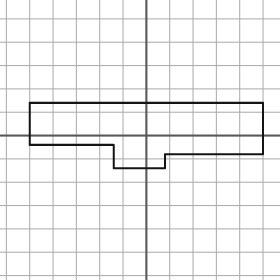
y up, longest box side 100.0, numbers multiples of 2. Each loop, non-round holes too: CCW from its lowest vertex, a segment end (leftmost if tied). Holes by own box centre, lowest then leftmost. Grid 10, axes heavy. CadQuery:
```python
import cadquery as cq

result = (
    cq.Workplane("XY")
    .moveTo(-14.0, -14.0)
    .lineTo(8.0, -14.0)
    .lineTo(8.0, -8.0)
    .lineTo(50.0, -8.0)
    .lineTo(50.0, 14.0)
    .lineTo(-50.0, 14.0)
    .lineTo(-50.0, -4.0)
    .lineTo(-14.0, -4.0)
    .close()
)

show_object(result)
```